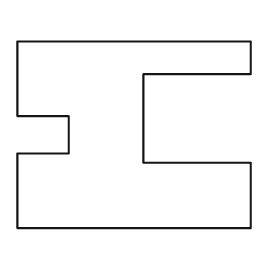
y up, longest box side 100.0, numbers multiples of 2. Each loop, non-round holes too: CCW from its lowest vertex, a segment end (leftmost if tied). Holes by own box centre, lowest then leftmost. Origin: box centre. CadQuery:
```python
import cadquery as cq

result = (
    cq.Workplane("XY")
    .moveTo(-50.0, -40.0)
    .lineTo(50.0, -40.0)
    .lineTo(50.0, -12.0)
    .lineTo(4.0, -12.0)
    .lineTo(4.0, 26.0)
    .lineTo(50.0, 26.0)
    .lineTo(50.0, 40.0)
    .lineTo(-50.0, 40.0)
    .lineTo(-50.0, 8.0)
    .lineTo(-28.0, 8.0)
    .lineTo(-28.0, -8.0)
    .lineTo(-50.0, -8.0)
    .close()
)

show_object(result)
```